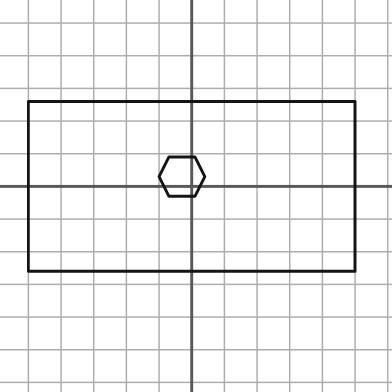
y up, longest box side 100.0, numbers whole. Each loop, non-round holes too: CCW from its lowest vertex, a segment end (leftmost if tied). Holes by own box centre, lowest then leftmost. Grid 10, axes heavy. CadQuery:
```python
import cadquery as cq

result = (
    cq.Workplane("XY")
    .moveTo(-50.0, -26.0)
    .lineTo(50.0, -26.0)
    .lineTo(50.0, 26.0)
    .lineTo(-50.0, 26.0)
    .close()
    .moveTo(-7.0, -3.0)
    .lineTo(1.0, -3.0)
    .lineTo(4.0, 3.0)
    .lineTo(1.0, 9.0)
    .lineTo(-7.0, 9.0)
    .lineTo(-10.0, 3.0)
    .close()
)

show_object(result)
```